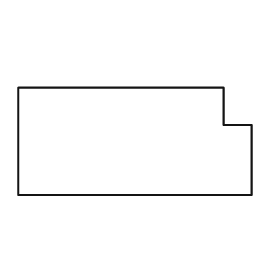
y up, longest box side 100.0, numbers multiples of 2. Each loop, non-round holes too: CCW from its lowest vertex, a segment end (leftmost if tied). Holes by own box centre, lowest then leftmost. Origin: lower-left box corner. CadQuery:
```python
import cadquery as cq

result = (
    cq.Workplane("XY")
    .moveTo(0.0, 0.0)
    .lineTo(100.0, 0.0)
    .lineTo(100.0, 30.0)
    .lineTo(88.0, 30.0)
    .lineTo(88.0, 46.0)
    .lineTo(0.0, 46.0)
    .close()
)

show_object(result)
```